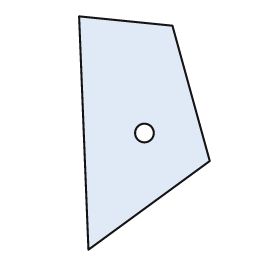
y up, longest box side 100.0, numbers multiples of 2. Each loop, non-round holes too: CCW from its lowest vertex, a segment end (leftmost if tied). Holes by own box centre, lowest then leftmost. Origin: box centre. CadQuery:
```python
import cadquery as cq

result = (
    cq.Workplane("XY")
    .moveTo(-24.0, -50.0)
    .lineTo(28.0, -12.0)
    .lineTo(12.0, 46.0)
    .lineTo(-28.0, 50.0)
    .close()
    .moveTo(0.0, 0.0)
    .circle(4.0)
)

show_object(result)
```